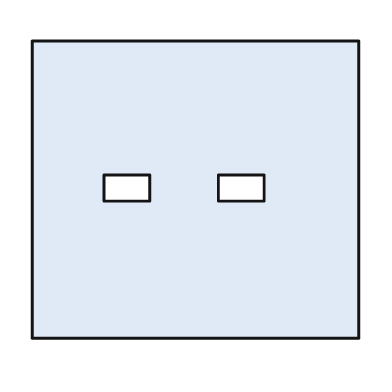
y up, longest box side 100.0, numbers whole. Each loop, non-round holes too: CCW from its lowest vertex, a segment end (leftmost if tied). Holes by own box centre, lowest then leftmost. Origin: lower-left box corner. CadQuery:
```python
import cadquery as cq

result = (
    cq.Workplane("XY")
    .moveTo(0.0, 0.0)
    .lineTo(100.0, 0.0)
    .lineTo(100.0, 91.0)
    .lineTo(0.0, 91.0)
    .close()
    .moveTo(22.0, 42.0)
    .lineTo(36.0, 42.0)
    .lineTo(36.0, 50.0)
    .lineTo(22.0, 50.0)
    .close()
    .moveTo(57.0, 42.0)
    .lineTo(71.0, 42.0)
    .lineTo(71.0, 50.0)
    .lineTo(57.0, 50.0)
    .close()
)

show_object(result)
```